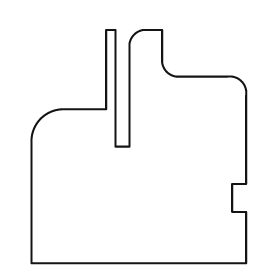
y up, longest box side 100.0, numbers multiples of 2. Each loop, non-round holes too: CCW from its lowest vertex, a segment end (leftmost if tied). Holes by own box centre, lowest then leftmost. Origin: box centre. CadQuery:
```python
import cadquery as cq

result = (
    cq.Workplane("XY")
    .moveTo(-46.0, -50.0)
    .lineTo(46.0, -50.0)
    .lineTo(46.0, -28.0)
    .lineTo(40.0, -28.0)
    .lineTo(40.0, -16.0)
    .lineTo(46.0, -16.0)
    .lineTo(46.0, 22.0)
    .threePointArc((44.0, 28.0), (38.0, 30.0))
    .lineTo(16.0, 30.0)
    .threePointArc((12.0, 32.0), (10.0, 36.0))
    .lineTo(10.0, 50.0)
    .lineTo(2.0, 50.0)
    .threePointArc((-2.0, 48.0), (-4.0, 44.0))
    .lineTo(-4.0, 0.0)
    .lineTo(-10.0, 0.0)
    .lineTo(-10.0, 50.0)
    .lineTo(-14.0, 50.0)
    .lineTo(-14.0, 16.0)
    .lineTo(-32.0, 16.0)
    .threePointArc((-42.0, 12.0), (-46.0, 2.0))
    .close()
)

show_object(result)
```